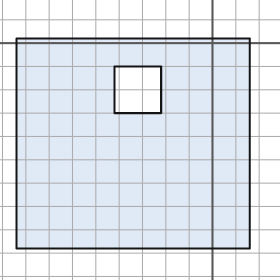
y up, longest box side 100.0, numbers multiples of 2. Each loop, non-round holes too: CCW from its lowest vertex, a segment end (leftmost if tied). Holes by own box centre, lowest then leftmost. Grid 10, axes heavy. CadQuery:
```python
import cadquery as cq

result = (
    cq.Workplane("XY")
    .moveTo(-84.0, -88.0)
    .lineTo(16.0, -88.0)
    .lineTo(16.0, 2.0)
    .lineTo(-84.0, 2.0)
    .close()
    .moveTo(-42.0, -30.0)
    .lineTo(-22.0, -30.0)
    .lineTo(-22.0, -10.0)
    .lineTo(-42.0, -10.0)
    .close()
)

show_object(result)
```